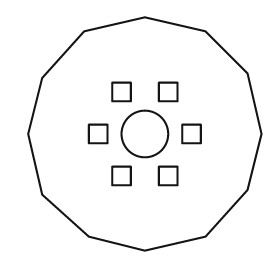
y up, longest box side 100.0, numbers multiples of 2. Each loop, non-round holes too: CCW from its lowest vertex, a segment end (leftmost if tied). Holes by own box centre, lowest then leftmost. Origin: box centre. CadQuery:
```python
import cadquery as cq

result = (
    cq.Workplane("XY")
    .moveTo(0.0, -50.0)
    .lineTo(26.0, -44.0)
    .lineTo(44.0, -24.0)
    .lineTo(50.0, 0.0)
    .lineTo(44.0, 26.0)
    .lineTo(26.0, 44.0)
    .lineTo(0.0, 50.0)
    .lineTo(-26.0, 44.0)
    .lineTo(-44.0, 24.0)
    .lineTo(-50.0, 0.0)
    .lineTo(-44.0, -26.0)
    .lineTo(-24.0, -44.0)
    .close()
    .moveTo(-14.0, -22.0)
    .lineTo(-6.0, -22.0)
    .lineTo(-6.0, -14.0)
    .lineTo(-14.0, -14.0)
    .close()
    .moveTo(6.0, -22.0)
    .lineTo(14.0, -22.0)
    .lineTo(14.0, -14.0)
    .lineTo(6.0, -14.0)
    .close()
    .moveTo(-24.0, -4.0)
    .lineTo(-16.0, -4.0)
    .lineTo(-16.0, 4.0)
    .lineTo(-24.0, 4.0)
    .close()
    .moveTo(0.0, 0.0)
    .circle(10.0)
    .moveTo(16.0, -4.0)
    .lineTo(24.0, -4.0)
    .lineTo(24.0, 4.0)
    .lineTo(16.0, 4.0)
    .close()
    .moveTo(-14.0, 14.0)
    .lineTo(-6.0, 14.0)
    .lineTo(-6.0, 22.0)
    .lineTo(-14.0, 22.0)
    .close()
    .moveTo(6.0, 14.0)
    .lineTo(14.0, 14.0)
    .lineTo(14.0, 22.0)
    .lineTo(6.0, 22.0)
    .close()
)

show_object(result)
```